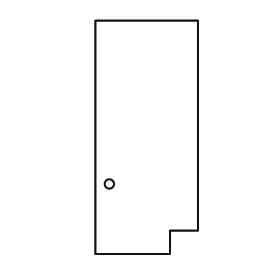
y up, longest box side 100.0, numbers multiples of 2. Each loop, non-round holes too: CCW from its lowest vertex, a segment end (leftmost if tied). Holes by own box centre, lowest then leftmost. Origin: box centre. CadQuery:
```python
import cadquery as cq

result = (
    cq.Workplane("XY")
    .moveTo(-22.0, -50.0)
    .lineTo(10.0, -50.0)
    .lineTo(10.0, -40.0)
    .lineTo(22.0, -40.0)
    .lineTo(22.0, 50.0)
    .lineTo(-22.0, 50.0)
    .close()
    .moveTo(-16.0, -20.0)
    .circle(2.0)
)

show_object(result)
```